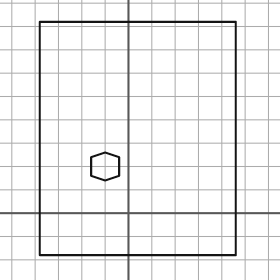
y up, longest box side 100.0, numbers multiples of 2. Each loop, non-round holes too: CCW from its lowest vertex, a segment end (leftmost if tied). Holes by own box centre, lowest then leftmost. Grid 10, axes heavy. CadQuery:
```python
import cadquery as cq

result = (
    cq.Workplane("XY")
    .moveTo(-38.0, -18.0)
    .lineTo(46.0, -18.0)
    .lineTo(46.0, 82.0)
    .lineTo(-38.0, 82.0)
    .close()
    .moveTo(-10.0, 14.0)
    .lineTo(-4.0, 16.0)
    .lineTo(-4.0, 24.0)
    .lineTo(-10.0, 26.0)
    .lineTo(-16.0, 24.0)
    .lineTo(-16.0, 16.0)
    .close()
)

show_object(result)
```